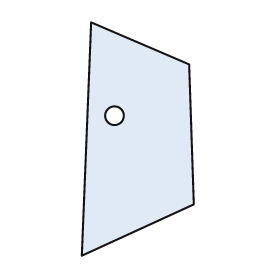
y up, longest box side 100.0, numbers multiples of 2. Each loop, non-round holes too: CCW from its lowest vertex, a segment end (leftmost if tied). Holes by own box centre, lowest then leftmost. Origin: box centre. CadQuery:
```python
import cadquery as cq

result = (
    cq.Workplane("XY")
    .moveTo(-24.0, -50.0)
    .lineTo(24.0, -28.0)
    .lineTo(22.0, 32.0)
    .lineTo(-20.0, 50.0)
    .close()
    .moveTo(-10.0, 10.0)
    .circle(4.0)
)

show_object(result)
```